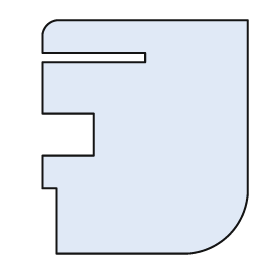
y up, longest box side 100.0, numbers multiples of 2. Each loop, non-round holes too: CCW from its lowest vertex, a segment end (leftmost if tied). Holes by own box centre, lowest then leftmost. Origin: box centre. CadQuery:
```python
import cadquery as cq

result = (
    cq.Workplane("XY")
    .moveTo(-38.0, -50.0)
    .lineTo(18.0, -50.0)
    .threePointArc((36.0, -42.0), (44.0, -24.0))
    .lineTo(44.0, 50.0)
    .lineTo(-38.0, 50.0)
    .threePointArc((-42.0, 48.0), (-44.0, 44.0))
    .lineTo(-44.0, 36.0)
    .lineTo(0.0, 36.0)
    .lineTo(0.0, 32.0)
    .lineTo(-44.0, 32.0)
    .lineTo(-44.0, 10.0)
    .lineTo(-22.0, 10.0)
    .lineTo(-22.0, -8.0)
    .lineTo(-44.0, -8.0)
    .lineTo(-44.0, -22.0)
    .lineTo(-38.0, -22.0)
    .close()
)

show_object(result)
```